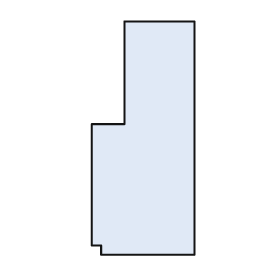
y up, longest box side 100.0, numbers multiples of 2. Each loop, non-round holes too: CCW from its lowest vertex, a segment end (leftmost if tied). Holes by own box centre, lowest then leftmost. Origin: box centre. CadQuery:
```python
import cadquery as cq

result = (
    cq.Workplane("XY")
    .moveTo(-18.0, -50.0)
    .lineTo(22.0, -50.0)
    .lineTo(22.0, 50.0)
    .lineTo(-8.0, 50.0)
    .lineTo(-8.0, 6.0)
    .lineTo(-22.0, 6.0)
    .lineTo(-22.0, -46.0)
    .lineTo(-18.0, -46.0)
    .close()
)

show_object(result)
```